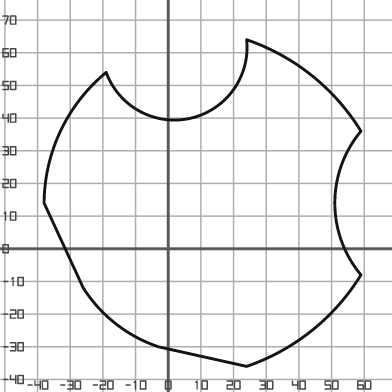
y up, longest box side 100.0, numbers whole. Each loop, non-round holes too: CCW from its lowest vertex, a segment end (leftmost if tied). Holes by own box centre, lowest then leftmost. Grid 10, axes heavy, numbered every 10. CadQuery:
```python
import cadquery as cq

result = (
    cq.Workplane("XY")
    .moveTo(24.0, -36.0)
    .threePointArc((44.0, -25.0), (59.0, -8.0))
    .threePointArc((51.0, 14.0), (59.0, 36.0))
    .threePointArc((44.0, 53.0), (24.0, 64.0))
    .threePointArc((7.0, 40.0), (-19.0, 54.0))
    .threePointArc((-33.0, 36.0), (-38.0, 14.0))
    .lineTo(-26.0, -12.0)
    .threePointArc((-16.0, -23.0), (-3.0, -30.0))
    .close()
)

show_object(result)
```